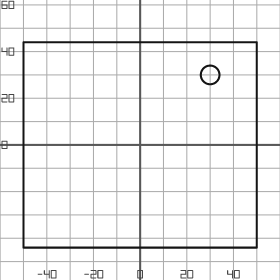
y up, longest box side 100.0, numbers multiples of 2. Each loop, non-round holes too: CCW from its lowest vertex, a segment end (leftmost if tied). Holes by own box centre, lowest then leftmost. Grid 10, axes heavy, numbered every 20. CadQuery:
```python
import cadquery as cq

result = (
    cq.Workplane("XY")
    .moveTo(-50.0, -44.0)
    .lineTo(50.0, -44.0)
    .lineTo(50.0, 44.0)
    .lineTo(-50.0, 44.0)
    .close()
    .moveTo(30.0, 30.0)
    .circle(4.0)
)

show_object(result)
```